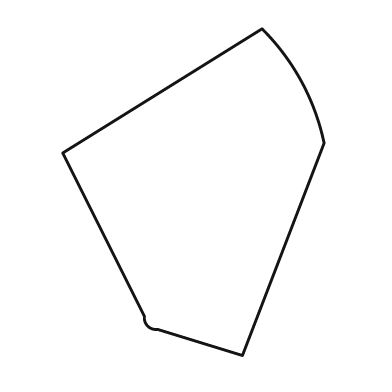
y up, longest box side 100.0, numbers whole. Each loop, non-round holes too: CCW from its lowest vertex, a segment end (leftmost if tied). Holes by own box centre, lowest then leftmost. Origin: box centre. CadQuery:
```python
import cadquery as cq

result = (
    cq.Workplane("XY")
    .moveTo(15.0, -50.0)
    .lineTo(40.0, 15.0)
    .threePointArc((33.0, 34.0), (21.0, 50.0))
    .lineTo(-40.0, 12.0)
    .lineTo(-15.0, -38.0)
    .threePointArc((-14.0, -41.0), (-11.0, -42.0))
    .close()
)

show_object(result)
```